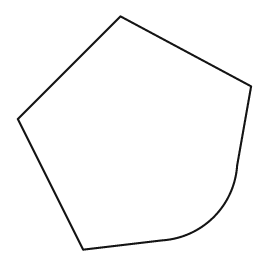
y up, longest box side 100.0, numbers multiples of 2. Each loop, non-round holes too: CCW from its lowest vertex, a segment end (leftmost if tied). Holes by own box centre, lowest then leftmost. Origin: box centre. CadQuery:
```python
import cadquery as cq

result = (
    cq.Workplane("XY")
    .moveTo(-22.0, -50.0)
    .lineTo(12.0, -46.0)
    .threePointArc((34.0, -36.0), (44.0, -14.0))
    .lineTo(50.0, 20.0)
    .lineTo(-6.0, 50.0)
    .lineTo(-50.0, 6.0)
    .close()
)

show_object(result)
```